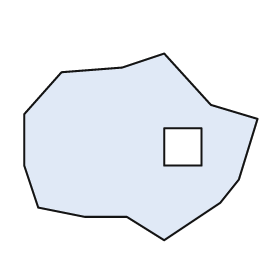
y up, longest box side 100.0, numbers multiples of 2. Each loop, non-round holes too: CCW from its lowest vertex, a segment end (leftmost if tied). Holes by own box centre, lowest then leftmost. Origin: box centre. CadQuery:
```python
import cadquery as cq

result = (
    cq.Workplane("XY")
    .moveTo(10.0, -40.0)
    .lineTo(34.0, -24.0)
    .lineTo(42.0, -14.0)
    .lineTo(50.0, 12.0)
    .lineTo(30.0, 18.0)
    .lineTo(10.0, 40.0)
    .lineTo(-8.0, 34.0)
    .lineTo(-34.0, 32.0)
    .lineTo(-50.0, 14.0)
    .lineTo(-50.0, -8.0)
    .lineTo(-44.0, -26.0)
    .lineTo(-24.0, -30.0)
    .lineTo(-6.0, -30.0)
    .close()
    .moveTo(10.0, -8.0)
    .lineTo(26.0, -8.0)
    .lineTo(26.0, 8.0)
    .lineTo(10.0, 8.0)
    .close()
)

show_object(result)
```